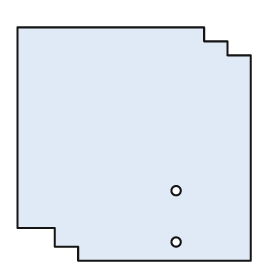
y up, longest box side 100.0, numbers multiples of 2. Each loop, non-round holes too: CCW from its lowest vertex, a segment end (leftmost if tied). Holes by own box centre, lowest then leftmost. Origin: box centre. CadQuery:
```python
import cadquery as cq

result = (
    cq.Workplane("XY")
    .moveTo(-24.0, -50.0)
    .lineTo(50.0, -50.0)
    .lineTo(50.0, 38.0)
    .lineTo(40.0, 38.0)
    .lineTo(40.0, 44.0)
    .lineTo(30.0, 44.0)
    .lineTo(30.0, 50.0)
    .lineTo(-50.0, 50.0)
    .lineTo(-50.0, -36.0)
    .lineTo(-34.0, -36.0)
    .lineTo(-34.0, -44.0)
    .lineTo(-24.0, -44.0)
    .close()
    .moveTo(18.0, -42.0)
    .circle(2.0)
    .moveTo(18.0, -20.0)
    .circle(2.0)
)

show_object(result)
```